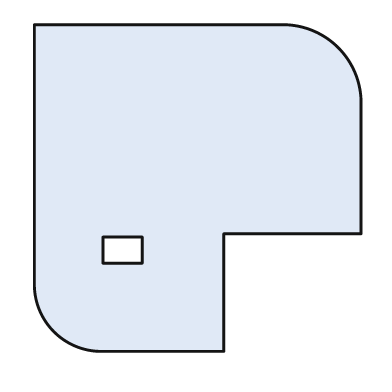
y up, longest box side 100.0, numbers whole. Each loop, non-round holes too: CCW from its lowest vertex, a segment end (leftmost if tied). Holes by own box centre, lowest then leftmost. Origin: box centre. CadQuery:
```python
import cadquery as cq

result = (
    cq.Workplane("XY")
    .moveTo(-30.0, -50.0)
    .lineTo(8.0, -50.0)
    .lineTo(8.0, -14.0)
    .lineTo(50.0, -14.0)
    .lineTo(50.0, 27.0)
    .threePointArc((43.0, 43.0), (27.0, 50.0))
    .lineTo(-50.0, 50.0)
    .lineTo(-50.0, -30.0)
    .threePointArc((-44.0, -44.0), (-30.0, -50.0))
    .close()
    .moveTo(-29.0, -23.0)
    .lineTo(-17.0, -23.0)
    .lineTo(-17.0, -15.0)
    .lineTo(-29.0, -15.0)
    .close()
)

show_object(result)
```